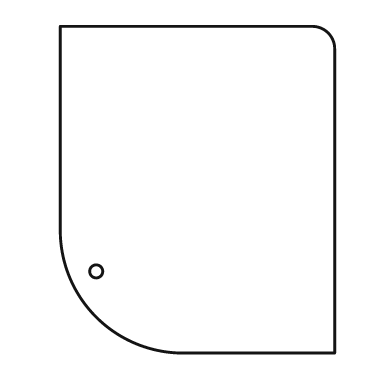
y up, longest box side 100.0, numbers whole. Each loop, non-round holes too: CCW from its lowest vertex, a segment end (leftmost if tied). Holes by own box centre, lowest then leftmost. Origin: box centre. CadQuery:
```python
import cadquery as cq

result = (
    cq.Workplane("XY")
    .moveTo(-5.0, -50.0)
    .lineTo(42.0, -50.0)
    .lineTo(42.0, 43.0)
    .threePointArc((40.0, 48.0), (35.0, 50.0))
    .lineTo(-42.0, 50.0)
    .lineTo(-42.0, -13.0)
    .threePointArc((-31.0, -39.0), (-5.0, -50.0))
    .close()
    .moveTo(-31.0, -25.0)
    .circle(2.0)
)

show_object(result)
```